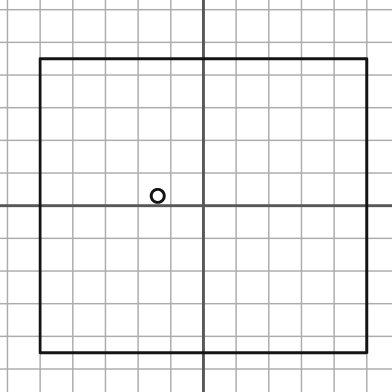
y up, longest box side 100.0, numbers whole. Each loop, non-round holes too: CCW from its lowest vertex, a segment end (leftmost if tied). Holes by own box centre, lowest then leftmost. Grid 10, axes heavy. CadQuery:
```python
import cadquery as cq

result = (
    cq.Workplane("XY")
    .moveTo(-50.0, -45.0)
    .lineTo(50.0, -45.0)
    .lineTo(50.0, 45.0)
    .lineTo(-50.0, 45.0)
    .close()
    .moveTo(-14.0, 3.0)
    .circle(2.0)
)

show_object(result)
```